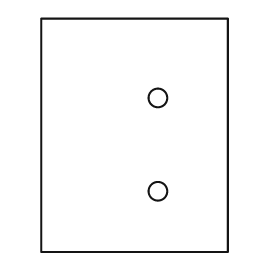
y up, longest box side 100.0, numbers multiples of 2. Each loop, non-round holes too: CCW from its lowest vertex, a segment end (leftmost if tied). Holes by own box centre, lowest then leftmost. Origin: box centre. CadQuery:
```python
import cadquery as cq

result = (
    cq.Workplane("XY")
    .moveTo(-40.0, -50.0)
    .lineTo(40.0, -50.0)
    .lineTo(40.0, 50.0)
    .lineTo(-40.0, 50.0)
    .close()
    .moveTo(10.0, -24.0)
    .circle(4.0)
    .moveTo(10.0, 16.0)
    .circle(4.0)
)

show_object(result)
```